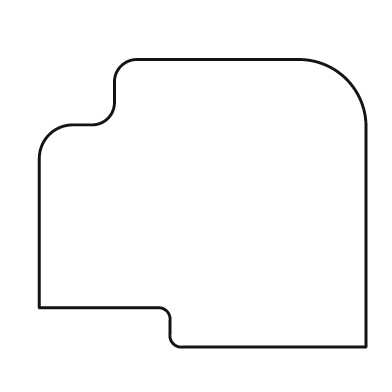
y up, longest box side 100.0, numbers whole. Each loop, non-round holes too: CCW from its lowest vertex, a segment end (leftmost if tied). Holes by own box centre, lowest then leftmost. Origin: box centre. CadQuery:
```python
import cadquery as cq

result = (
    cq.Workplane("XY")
    .moveTo(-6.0, -44.0)
    .lineTo(50.0, -44.0)
    .lineTo(50.0, 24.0)
    .threePointArc((44.0, 38.0), (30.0, 44.0))
    .lineTo(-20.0, 44.0)
    .threePointArc((-25.0, 42.0), (-27.0, 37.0))
    .lineTo(-27.0, 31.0)
    .threePointArc((-29.0, 26.0), (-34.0, 24.0))
    .lineTo(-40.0, 24.0)
    .threePointArc((-47.0, 21.0), (-50.0, 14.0))
    .lineTo(-50.0, -32.0)
    .lineTo(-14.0, -32.0)
    .threePointArc((-11.0, -33.0), (-10.0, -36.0))
    .lineTo(-10.0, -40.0)
    .threePointArc((-9.0, -43.0), (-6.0, -44.0))
    .close()
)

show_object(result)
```